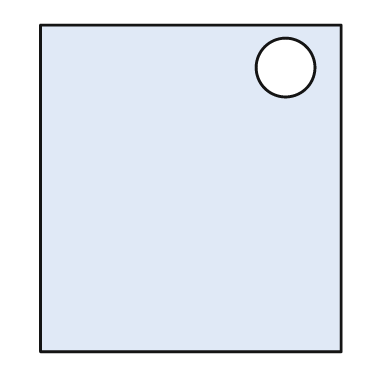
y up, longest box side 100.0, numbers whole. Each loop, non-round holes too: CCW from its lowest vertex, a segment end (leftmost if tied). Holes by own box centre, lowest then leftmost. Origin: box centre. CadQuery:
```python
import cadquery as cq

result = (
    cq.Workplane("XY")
    .moveTo(-46.0, -50.0)
    .lineTo(46.0, -50.0)
    .lineTo(46.0, 50.0)
    .lineTo(-46.0, 50.0)
    .close()
    .moveTo(29.0, 37.0)
    .circle(9.0)
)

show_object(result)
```